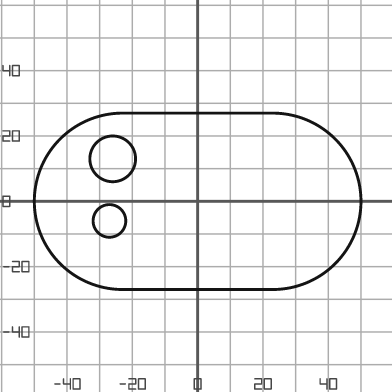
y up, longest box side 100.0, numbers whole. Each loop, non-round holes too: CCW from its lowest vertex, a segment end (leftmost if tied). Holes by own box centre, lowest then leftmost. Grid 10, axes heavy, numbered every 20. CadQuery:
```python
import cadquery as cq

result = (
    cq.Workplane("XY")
    .moveTo(-23.0, -27.0)
    .lineTo(23.0, -27.0)
    .threePointArc((50.0, 0.0), (23.0, 27.0))
    .lineTo(-23.0, 27.0)
    .threePointArc((-50.0, 0.0), (-23.0, -27.0))
    .close()
    .moveTo(-27.0, -6.0)
    .circle(5.0)
    .moveTo(-26.0, 13.0)
    .circle(7.0)
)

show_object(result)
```